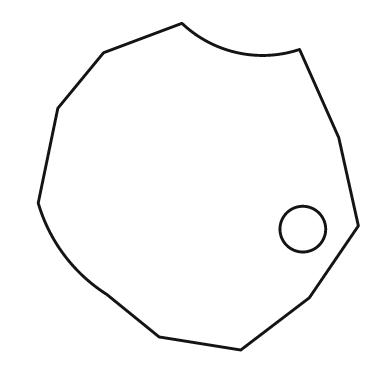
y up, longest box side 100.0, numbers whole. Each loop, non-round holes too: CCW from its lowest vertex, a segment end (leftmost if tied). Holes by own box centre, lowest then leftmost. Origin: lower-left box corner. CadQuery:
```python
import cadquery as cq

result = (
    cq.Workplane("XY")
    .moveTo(62.0, 0.0)
    .lineTo(83.0, 16.0)
    .lineTo(98.0, 38.0)
    .lineTo(92.0, 65.0)
    .lineTo(80.0, 92.0)
    .threePointArc((61.0, 91.0), (44.0, 100.0))
    .lineTo(20.0, 91.0)
    .lineTo(6.0, 74.0)
    .lineTo(0.0, 45.0)
    .threePointArc((8.0, 29.0), (21.0, 17.0))
    .lineTo(37.0, 4.0)
    .close()
    .moveTo(81.0, 37.0)
    .circle(7.0)
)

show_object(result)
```